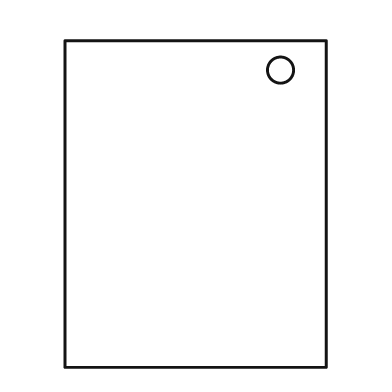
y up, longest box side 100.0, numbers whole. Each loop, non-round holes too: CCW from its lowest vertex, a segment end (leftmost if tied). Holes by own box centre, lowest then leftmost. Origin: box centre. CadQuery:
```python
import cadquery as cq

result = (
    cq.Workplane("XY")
    .moveTo(-40.0, -50.0)
    .lineTo(40.0, -50.0)
    .lineTo(40.0, 50.0)
    .lineTo(-40.0, 50.0)
    .close()
    .moveTo(26.0, 41.0)
    .circle(4.0)
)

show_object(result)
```